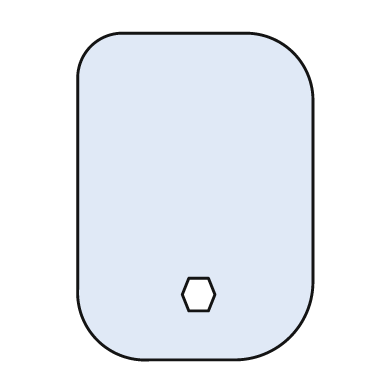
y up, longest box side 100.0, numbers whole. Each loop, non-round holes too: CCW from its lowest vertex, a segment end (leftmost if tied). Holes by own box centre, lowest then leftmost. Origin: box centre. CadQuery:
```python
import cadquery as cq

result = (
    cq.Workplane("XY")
    .moveTo(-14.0, -50.0)
    .lineTo(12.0, -50.0)
    .threePointArc((29.0, -43.0), (36.0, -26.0))
    .lineTo(36.0, 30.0)
    .threePointArc((30.0, 44.0), (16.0, 50.0))
    .lineTo(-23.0, 50.0)
    .threePointArc((-32.0, 46.0), (-36.0, 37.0))
    .lineTo(-36.0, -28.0)
    .threePointArc((-30.0, -44.0), (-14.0, -50.0))
    .close()
    .moveTo(-2.0, -35.0)
    .lineTo(4.0, -35.0)
    .lineTo(6.0, -30.0)
    .lineTo(4.0, -25.0)
    .lineTo(-2.0, -25.0)
    .lineTo(-4.0, -30.0)
    .close()
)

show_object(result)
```